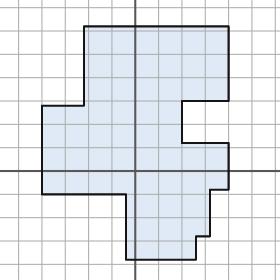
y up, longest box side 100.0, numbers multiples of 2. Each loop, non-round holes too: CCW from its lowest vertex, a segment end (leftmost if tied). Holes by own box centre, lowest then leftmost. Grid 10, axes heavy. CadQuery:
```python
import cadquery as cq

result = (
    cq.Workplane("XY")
    .moveTo(-4.0, -38.0)
    .lineTo(26.0, -38.0)
    .lineTo(26.0, -28.0)
    .lineTo(32.0, -28.0)
    .lineTo(32.0, -8.0)
    .lineTo(40.0, -8.0)
    .lineTo(40.0, 12.0)
    .lineTo(20.0, 12.0)
    .lineTo(20.0, 30.0)
    .lineTo(40.0, 30.0)
    .lineTo(40.0, 62.0)
    .lineTo(-22.0, 62.0)
    .lineTo(-22.0, 28.0)
    .lineTo(-40.0, 28.0)
    .lineTo(-40.0, -10.0)
    .lineTo(-4.0, -10.0)
    .close()
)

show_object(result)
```